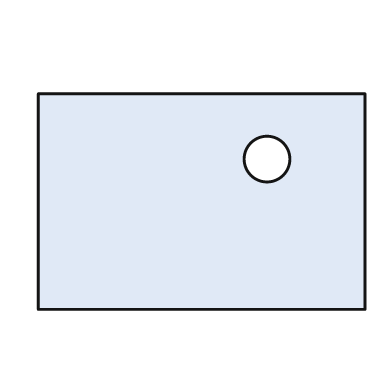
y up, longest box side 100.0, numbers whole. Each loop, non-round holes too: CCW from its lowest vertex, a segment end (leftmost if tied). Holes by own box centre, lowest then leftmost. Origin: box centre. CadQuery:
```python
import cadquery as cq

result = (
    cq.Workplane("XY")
    .moveTo(-50.0, -33.0)
    .lineTo(50.0, -33.0)
    .lineTo(50.0, 33.0)
    .lineTo(-50.0, 33.0)
    .close()
    .moveTo(20.0, 13.0)
    .circle(7.0)
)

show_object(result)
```